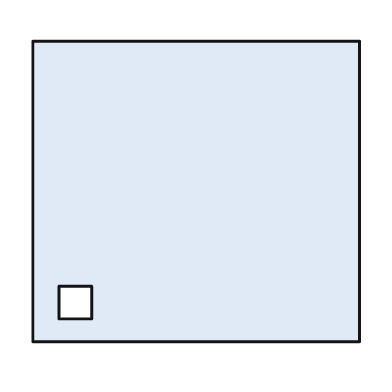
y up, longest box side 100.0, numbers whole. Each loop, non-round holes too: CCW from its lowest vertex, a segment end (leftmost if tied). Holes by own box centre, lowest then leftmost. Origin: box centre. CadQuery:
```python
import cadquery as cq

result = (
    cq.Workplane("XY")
    .moveTo(-50.0, -46.0)
    .lineTo(50.0, -46.0)
    .lineTo(50.0, 46.0)
    .lineTo(-50.0, 46.0)
    .close()
    .moveTo(-42.0, -39.0)
    .lineTo(-32.0, -39.0)
    .lineTo(-32.0, -29.0)
    .lineTo(-42.0, -29.0)
    .close()
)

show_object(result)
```